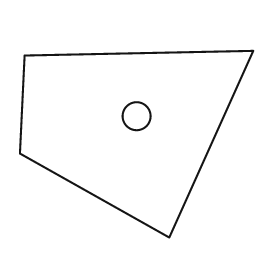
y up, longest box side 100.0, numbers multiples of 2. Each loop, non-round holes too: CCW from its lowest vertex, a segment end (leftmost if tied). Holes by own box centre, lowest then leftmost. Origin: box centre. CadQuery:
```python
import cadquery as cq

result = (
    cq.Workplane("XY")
    .moveTo(14.0, -40.0)
    .lineTo(50.0, 40.0)
    .lineTo(-48.0, 38.0)
    .lineTo(-50.0, -4.0)
    .close()
    .moveTo(0.0, 12.0)
    .circle(6.0)
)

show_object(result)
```